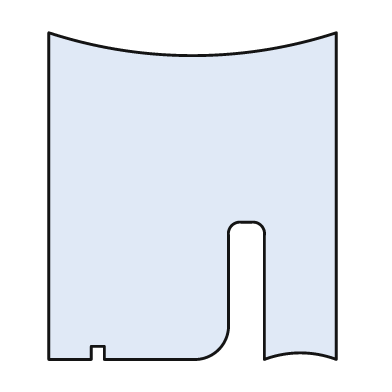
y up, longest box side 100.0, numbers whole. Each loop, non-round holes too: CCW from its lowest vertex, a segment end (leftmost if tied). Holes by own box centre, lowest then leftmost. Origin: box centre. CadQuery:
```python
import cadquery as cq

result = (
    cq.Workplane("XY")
    .moveTo(-44.0, -50.0)
    .lineTo(-31.0, -50.0)
    .lineTo(-31.0, -46.0)
    .lineTo(-27.0, -46.0)
    .lineTo(-27.0, -50.0)
    .lineTo(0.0, -50.0)
    .threePointArc((8.0, -47.0), (11.0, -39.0))
    .lineTo(11.0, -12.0)
    .threePointArc((12.0, -9.0), (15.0, -8.0))
    .lineTo(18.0, -8.0)
    .threePointArc((21.0, -9.0), (22.0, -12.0))
    .lineTo(22.0, -50.0)
    .threePointArc((33.0, -48.0), (44.0, -50.0))
    .lineTo(44.0, 50.0)
    .threePointArc((0.0, 43.0), (-44.0, 50.0))
    .close()
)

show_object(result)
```